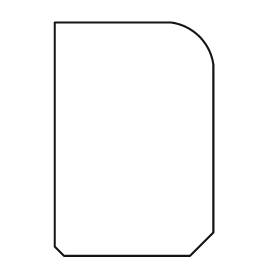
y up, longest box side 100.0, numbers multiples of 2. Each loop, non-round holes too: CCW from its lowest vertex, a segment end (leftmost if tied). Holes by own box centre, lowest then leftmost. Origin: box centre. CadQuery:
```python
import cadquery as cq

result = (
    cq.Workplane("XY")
    .moveTo(-30.0, -50.0)
    .lineTo(24.0, -50.0)
    .lineTo(34.0, -40.0)
    .lineTo(34.0, 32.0)
    .threePointArc((28.0, 44.0), (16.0, 50.0))
    .lineTo(-34.0, 50.0)
    .lineTo(-34.0, -46.0)
    .close()
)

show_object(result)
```